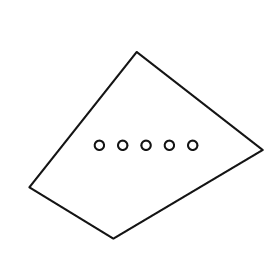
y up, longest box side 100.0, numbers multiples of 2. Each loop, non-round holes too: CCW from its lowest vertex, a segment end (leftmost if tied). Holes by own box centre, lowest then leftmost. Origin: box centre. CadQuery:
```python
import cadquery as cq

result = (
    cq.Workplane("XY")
    .moveTo(-14.0, -40.0)
    .lineTo(50.0, -2.0)
    .lineTo(-4.0, 40.0)
    .lineTo(-50.0, -18.0)
    .close()
    .moveTo(-20.0, 0.0)
    .circle(2.0)
    .moveTo(-10.0, 0.0)
    .circle(2.0)
    .moveTo(0.0, 0.0)
    .circle(2.0)
    .moveTo(10.0, 0.0)
    .circle(2.0)
    .moveTo(20.0, 0.0)
    .circle(2.0)
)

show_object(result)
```